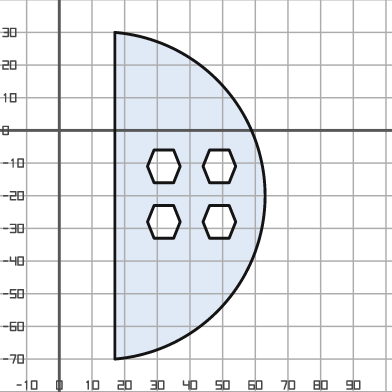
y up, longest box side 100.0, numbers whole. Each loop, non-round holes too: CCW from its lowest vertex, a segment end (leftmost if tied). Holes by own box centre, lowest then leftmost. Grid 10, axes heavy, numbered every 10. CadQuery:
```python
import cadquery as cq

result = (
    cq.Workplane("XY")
    .moveTo(17.0, -70.0)
    .threePointArc((63.0, -20.0), (17.0, 30.0))
    .close()
    .moveTo(29.0, -33.0)
    .lineTo(35.0, -33.0)
    .lineTo(37.0, -28.0)
    .lineTo(35.0, -23.0)
    .lineTo(29.0, -23.0)
    .lineTo(27.0, -28.0)
    .close()
    .moveTo(46.0, -33.0)
    .lineTo(52.0, -33.0)
    .lineTo(54.0, -28.0)
    .lineTo(52.0, -23.0)
    .lineTo(46.0, -23.0)
    .lineTo(44.0, -28.0)
    .close()
    .moveTo(29.0, -16.0)
    .lineTo(35.0, -16.0)
    .lineTo(37.0, -11.0)
    .lineTo(35.0, -6.0)
    .lineTo(29.0, -6.0)
    .lineTo(27.0, -11.0)
    .close()
    .moveTo(46.0, -16.0)
    .lineTo(52.0, -16.0)
    .lineTo(54.0, -11.0)
    .lineTo(52.0, -6.0)
    .lineTo(46.0, -6.0)
    .lineTo(44.0, -11.0)
    .close()
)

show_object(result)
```